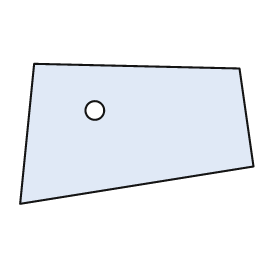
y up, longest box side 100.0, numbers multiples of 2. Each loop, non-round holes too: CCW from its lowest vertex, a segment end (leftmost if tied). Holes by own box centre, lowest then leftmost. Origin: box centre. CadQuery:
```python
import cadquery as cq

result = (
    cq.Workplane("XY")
    .moveTo(-50.0, -30.0)
    .lineTo(50.0, -14.0)
    .lineTo(44.0, 28.0)
    .lineTo(-44.0, 30.0)
    .close()
    .moveTo(-18.0, 10.0)
    .circle(4.0)
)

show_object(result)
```